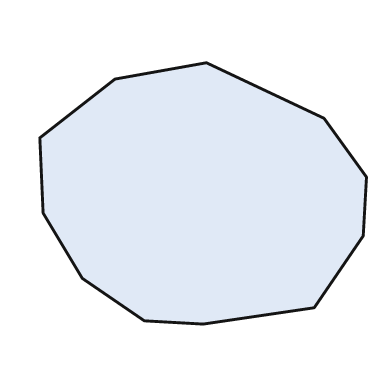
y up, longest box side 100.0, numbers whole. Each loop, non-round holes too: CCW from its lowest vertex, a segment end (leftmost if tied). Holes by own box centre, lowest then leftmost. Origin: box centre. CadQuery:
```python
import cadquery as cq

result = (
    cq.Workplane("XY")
    .moveTo(0.0, -40.0)
    .lineTo(34.0, -35.0)
    .lineTo(49.0, -13.0)
    .lineTo(50.0, 5.0)
    .lineTo(37.0, 23.0)
    .lineTo(1.0, 40.0)
    .lineTo(-27.0, 35.0)
    .lineTo(-50.0, 17.0)
    .lineTo(-49.0, -6.0)
    .lineTo(-37.0, -26.0)
    .lineTo(-18.0, -39.0)
    .close()
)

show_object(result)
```